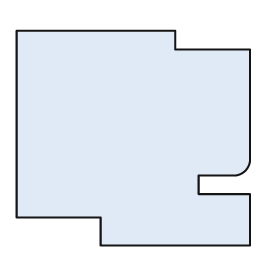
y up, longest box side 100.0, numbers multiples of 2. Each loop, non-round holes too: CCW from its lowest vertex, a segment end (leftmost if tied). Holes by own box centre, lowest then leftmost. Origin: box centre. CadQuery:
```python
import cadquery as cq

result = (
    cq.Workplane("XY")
    .moveTo(-14.0, -46.0)
    .lineTo(50.0, -46.0)
    .lineTo(50.0, -24.0)
    .lineTo(28.0, -24.0)
    .lineTo(28.0, -16.0)
    .lineTo(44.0, -16.0)
    .threePointArc((48.0, -14.0), (50.0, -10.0))
    .lineTo(50.0, 38.0)
    .lineTo(18.0, 38.0)
    .lineTo(18.0, 46.0)
    .lineTo(-50.0, 46.0)
    .lineTo(-50.0, -34.0)
    .lineTo(-14.0, -34.0)
    .close()
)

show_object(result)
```